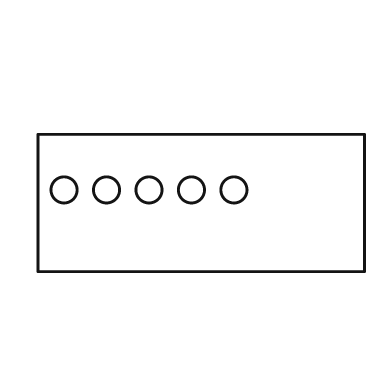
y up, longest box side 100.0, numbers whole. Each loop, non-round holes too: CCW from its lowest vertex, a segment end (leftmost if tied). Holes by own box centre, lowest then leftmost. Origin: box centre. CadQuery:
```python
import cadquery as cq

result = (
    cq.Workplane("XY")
    .moveTo(-50.0, -21.0)
    .lineTo(50.0, -21.0)
    .lineTo(50.0, 21.0)
    .lineTo(-50.0, 21.0)
    .close()
    .moveTo(-42.0, 4.0)
    .circle(4.0)
    .moveTo(-29.0, 4.0)
    .circle(4.0)
    .moveTo(-16.0, 4.0)
    .circle(4.0)
    .moveTo(-3.0, 4.0)
    .circle(4.0)
    .moveTo(10.0, 4.0)
    .circle(4.0)
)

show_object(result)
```